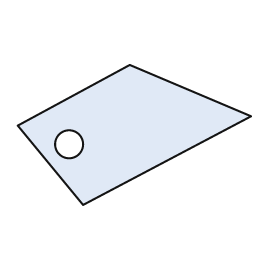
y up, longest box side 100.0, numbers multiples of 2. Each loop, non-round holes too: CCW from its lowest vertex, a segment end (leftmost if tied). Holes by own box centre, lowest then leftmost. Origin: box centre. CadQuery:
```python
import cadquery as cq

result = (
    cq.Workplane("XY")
    .moveTo(-22.0, -30.0)
    .lineTo(50.0, 8.0)
    .lineTo(-2.0, 30.0)
    .lineTo(-50.0, 4.0)
    .close()
    .moveTo(-28.0, -4.0)
    .circle(6.0)
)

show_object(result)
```